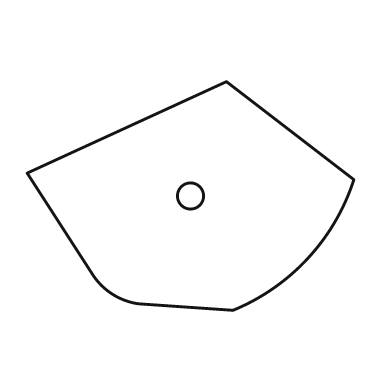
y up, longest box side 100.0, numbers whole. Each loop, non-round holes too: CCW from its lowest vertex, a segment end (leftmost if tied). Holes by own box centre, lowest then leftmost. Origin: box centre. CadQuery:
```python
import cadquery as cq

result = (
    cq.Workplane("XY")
    .moveTo(13.0, -35.0)
    .threePointArc((36.0, -19.0), (50.0, 5.0))
    .lineTo(11.0, 35.0)
    .lineTo(-50.0, 7.0)
    .lineTo(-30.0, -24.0)
    .threePointArc((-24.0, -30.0), (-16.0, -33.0))
    .close()
    .moveTo(0.0, 0.0)
    .circle(4.0)
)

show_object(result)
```